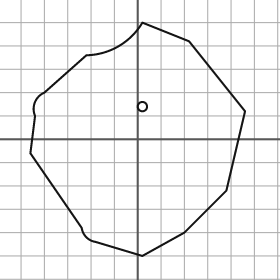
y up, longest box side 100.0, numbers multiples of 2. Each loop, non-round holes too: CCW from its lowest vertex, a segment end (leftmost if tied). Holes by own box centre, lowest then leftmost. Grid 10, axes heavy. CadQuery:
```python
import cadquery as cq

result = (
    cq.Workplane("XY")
    .moveTo(2.0, -50.0)
    .lineTo(20.0, -40.0)
    .lineTo(38.0, -22.0)
    .lineTo(46.0, 12.0)
    .lineTo(22.0, 42.0)
    .lineTo(2.0, 50.0)
    .threePointArc((-8.0, 40.0), (-22.0, 36.0))
    .lineTo(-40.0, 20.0)
    .threePointArc((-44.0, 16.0), (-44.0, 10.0))
    .lineTo(-46.0, -6.0)
    .lineTo(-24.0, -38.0)
    .threePointArc((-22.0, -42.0), (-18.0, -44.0))
    .close()
    .moveTo(2.0, 14.0)
    .circle(2.0)
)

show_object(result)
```